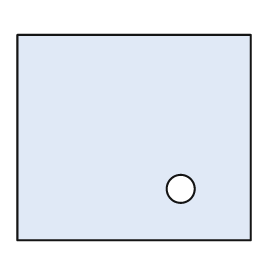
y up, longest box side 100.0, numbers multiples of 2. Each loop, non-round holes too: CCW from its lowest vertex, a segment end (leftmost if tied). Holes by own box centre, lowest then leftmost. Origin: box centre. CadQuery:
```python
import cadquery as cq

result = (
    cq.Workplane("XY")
    .moveTo(-50.0, -44.0)
    .lineTo(50.0, -44.0)
    .lineTo(50.0, 44.0)
    .lineTo(-50.0, 44.0)
    .close()
    .moveTo(20.0, -22.0)
    .circle(6.0)
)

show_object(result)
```